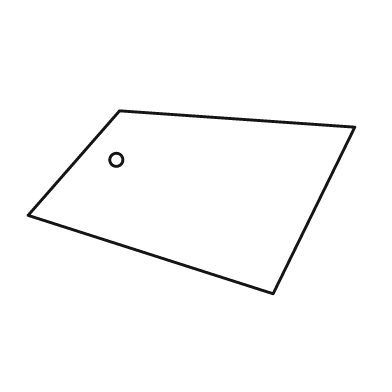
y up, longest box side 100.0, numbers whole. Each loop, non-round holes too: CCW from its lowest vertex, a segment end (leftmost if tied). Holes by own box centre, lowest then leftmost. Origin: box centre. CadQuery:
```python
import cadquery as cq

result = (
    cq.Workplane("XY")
    .moveTo(25.0, -28.0)
    .lineTo(50.0, 23.0)
    .lineTo(-22.0, 28.0)
    .lineTo(-50.0, -4.0)
    .close()
    .moveTo(-23.0, 13.0)
    .circle(2.0)
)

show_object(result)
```